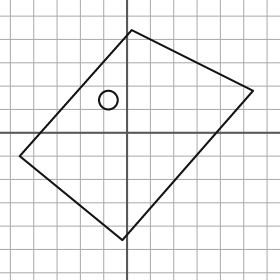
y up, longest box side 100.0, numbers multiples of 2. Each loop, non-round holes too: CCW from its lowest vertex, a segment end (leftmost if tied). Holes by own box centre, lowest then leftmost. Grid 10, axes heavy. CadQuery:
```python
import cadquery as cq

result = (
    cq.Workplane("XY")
    .moveTo(-2.0, -46.0)
    .lineTo(54.0, 18.0)
    .lineTo(2.0, 44.0)
    .lineTo(-46.0, -10.0)
    .close()
    .moveTo(-8.0, 14.0)
    .circle(4.0)
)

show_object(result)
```